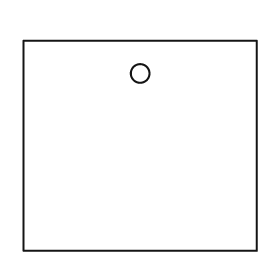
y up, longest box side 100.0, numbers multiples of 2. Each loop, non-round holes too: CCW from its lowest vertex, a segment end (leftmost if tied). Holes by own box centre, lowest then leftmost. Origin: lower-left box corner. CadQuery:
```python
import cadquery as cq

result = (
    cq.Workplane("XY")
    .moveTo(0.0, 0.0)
    .lineTo(100.0, 0.0)
    .lineTo(100.0, 90.0)
    .lineTo(0.0, 90.0)
    .close()
    .moveTo(50.0, 76.0)
    .circle(4.0)
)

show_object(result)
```